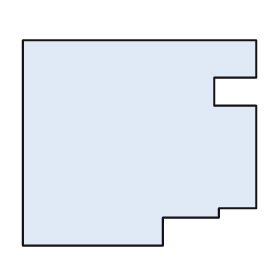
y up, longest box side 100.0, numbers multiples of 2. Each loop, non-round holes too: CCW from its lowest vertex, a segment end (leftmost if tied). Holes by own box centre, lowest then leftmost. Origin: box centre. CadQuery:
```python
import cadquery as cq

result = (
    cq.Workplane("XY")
    .moveTo(-50.0, -44.0)
    .lineTo(10.0, -44.0)
    .lineTo(10.0, -32.0)
    .lineTo(34.0, -32.0)
    .lineTo(34.0, -28.0)
    .lineTo(50.0, -28.0)
    .lineTo(50.0, 16.0)
    .lineTo(32.0, 16.0)
    .lineTo(32.0, 28.0)
    .lineTo(50.0, 28.0)
    .lineTo(50.0, 44.0)
    .lineTo(-50.0, 44.0)
    .close()
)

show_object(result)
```